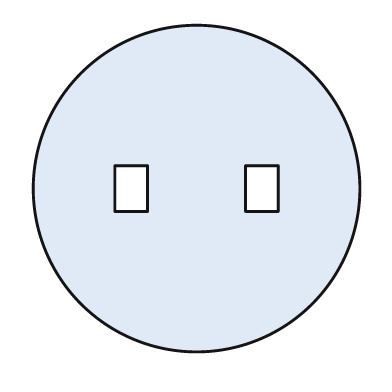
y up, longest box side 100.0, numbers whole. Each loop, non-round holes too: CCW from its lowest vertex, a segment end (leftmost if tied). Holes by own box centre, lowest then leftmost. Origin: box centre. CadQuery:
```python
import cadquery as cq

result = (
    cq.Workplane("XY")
    .moveTo(0.0, 0.0)
    .circle(50.0)
    .moveTo(-25.0, -7.0)
    .lineTo(-15.0, -7.0)
    .lineTo(-15.0, 7.0)
    .lineTo(-25.0, 7.0)
    .close()
    .moveTo(15.0, -7.0)
    .lineTo(25.0, -7.0)
    .lineTo(25.0, 7.0)
    .lineTo(15.0, 7.0)
    .close()
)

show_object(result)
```